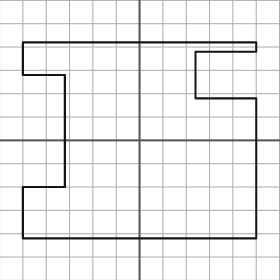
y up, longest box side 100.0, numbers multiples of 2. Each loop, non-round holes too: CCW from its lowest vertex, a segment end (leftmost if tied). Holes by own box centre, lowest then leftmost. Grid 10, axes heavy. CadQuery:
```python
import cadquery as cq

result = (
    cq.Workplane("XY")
    .moveTo(-50.0, -42.0)
    .lineTo(50.0, -42.0)
    .lineTo(50.0, 18.0)
    .lineTo(24.0, 18.0)
    .lineTo(24.0, 38.0)
    .lineTo(50.0, 38.0)
    .lineTo(50.0, 42.0)
    .lineTo(-50.0, 42.0)
    .lineTo(-50.0, 28.0)
    .lineTo(-32.0, 28.0)
    .lineTo(-32.0, -20.0)
    .lineTo(-50.0, -20.0)
    .close()
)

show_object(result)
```